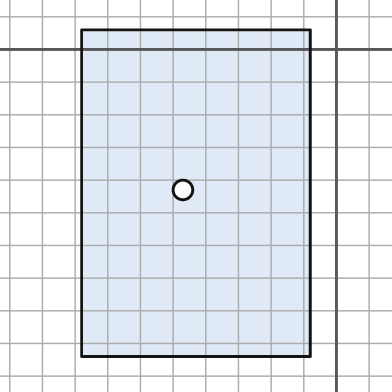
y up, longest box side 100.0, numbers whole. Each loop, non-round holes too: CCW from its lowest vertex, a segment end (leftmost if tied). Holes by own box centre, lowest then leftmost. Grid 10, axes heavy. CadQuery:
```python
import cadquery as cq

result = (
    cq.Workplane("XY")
    .moveTo(-78.0, -94.0)
    .lineTo(-8.0, -94.0)
    .lineTo(-8.0, 6.0)
    .lineTo(-78.0, 6.0)
    .close()
    .moveTo(-47.0, -43.0)
    .circle(3.0)
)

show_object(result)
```